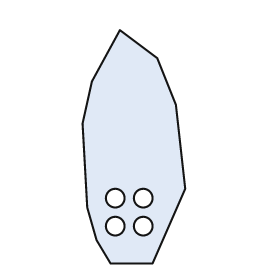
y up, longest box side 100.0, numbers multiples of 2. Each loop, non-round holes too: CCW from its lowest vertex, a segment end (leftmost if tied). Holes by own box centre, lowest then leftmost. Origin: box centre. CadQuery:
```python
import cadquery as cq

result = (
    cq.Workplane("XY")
    .moveTo(-10.0, -50.0)
    .lineTo(8.0, -50.0)
    .lineTo(22.0, -18.0)
    .lineTo(18.0, 18.0)
    .lineTo(10.0, 38.0)
    .lineTo(-6.0, 50.0)
    .lineTo(-18.0, 28.0)
    .lineTo(-22.0, 10.0)
    .lineTo(-20.0, -26.0)
    .lineTo(-16.0, -40.0)
    .close()
    .moveTo(-8.0, -34.0)
    .circle(4.0)
    .moveTo(4.0, -34.0)
    .circle(4.0)
    .moveTo(-8.0, -22.0)
    .circle(4.0)
    .moveTo(4.0, -22.0)
    .circle(4.0)
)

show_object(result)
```